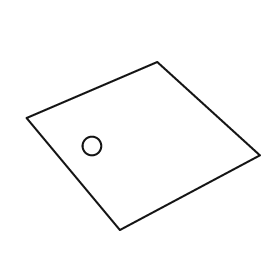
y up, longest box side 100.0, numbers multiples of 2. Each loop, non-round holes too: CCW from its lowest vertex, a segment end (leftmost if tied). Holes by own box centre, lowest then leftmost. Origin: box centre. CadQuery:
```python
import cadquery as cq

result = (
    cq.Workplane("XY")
    .moveTo(-10.0, -36.0)
    .lineTo(50.0, -4.0)
    .lineTo(6.0, 36.0)
    .lineTo(-50.0, 12.0)
    .close()
    .moveTo(-22.0, 0.0)
    .circle(4.0)
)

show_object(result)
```